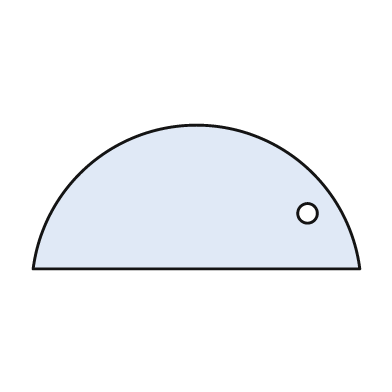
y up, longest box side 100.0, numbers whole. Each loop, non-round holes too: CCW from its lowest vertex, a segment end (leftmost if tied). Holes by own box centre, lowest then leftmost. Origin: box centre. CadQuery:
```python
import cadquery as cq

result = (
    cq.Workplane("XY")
    .moveTo(-50.0, -22.0)
    .lineTo(50.0, -22.0)
    .threePointArc((0.0, 22.0), (-50.0, -22.0))
    .close()
    .moveTo(34.0, -5.0)
    .circle(3.0)
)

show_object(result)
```